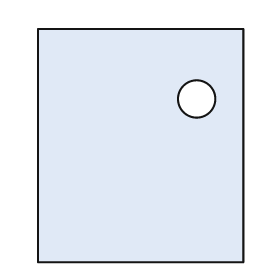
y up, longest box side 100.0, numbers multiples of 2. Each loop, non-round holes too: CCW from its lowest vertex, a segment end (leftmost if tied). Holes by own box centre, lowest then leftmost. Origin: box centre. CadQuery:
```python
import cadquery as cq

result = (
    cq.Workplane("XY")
    .moveTo(-44.0, -50.0)
    .lineTo(44.0, -50.0)
    .lineTo(44.0, 50.0)
    .lineTo(-44.0, 50.0)
    .close()
    .moveTo(24.0, 20.0)
    .circle(8.0)
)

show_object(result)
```